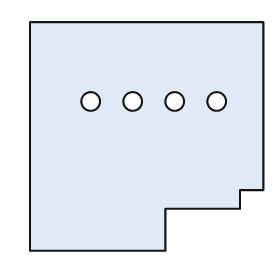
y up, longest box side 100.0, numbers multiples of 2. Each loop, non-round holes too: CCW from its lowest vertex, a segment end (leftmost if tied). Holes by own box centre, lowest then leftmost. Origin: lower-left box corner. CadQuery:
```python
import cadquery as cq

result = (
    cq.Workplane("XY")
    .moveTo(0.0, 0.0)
    .lineTo(58.0, 0.0)
    .lineTo(58.0, 18.0)
    .lineTo(90.0, 18.0)
    .lineTo(90.0, 26.0)
    .lineTo(100.0, 26.0)
    .lineTo(100.0, 98.0)
    .lineTo(0.0, 98.0)
    .close()
    .moveTo(26.0, 64.0)
    .circle(4.0)
    .moveTo(44.0, 64.0)
    .circle(4.0)
    .moveTo(62.0, 64.0)
    .circle(4.0)
    .moveTo(80.0, 64.0)
    .circle(4.0)
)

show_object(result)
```